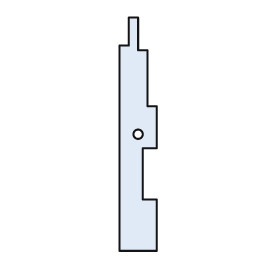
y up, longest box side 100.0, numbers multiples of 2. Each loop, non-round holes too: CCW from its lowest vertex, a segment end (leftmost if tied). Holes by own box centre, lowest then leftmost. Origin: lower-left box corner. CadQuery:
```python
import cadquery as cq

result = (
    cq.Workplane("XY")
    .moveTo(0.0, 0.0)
    .lineTo(16.0, 0.0)
    .lineTo(16.0, 22.0)
    .lineTo(10.0, 22.0)
    .lineTo(10.0, 44.0)
    .lineTo(16.0, 44.0)
    .lineTo(16.0, 62.0)
    .lineTo(12.0, 62.0)
    .lineTo(12.0, 86.0)
    .lineTo(8.0, 86.0)
    .lineTo(8.0, 100.0)
    .lineTo(4.0, 100.0)
    .lineTo(4.0, 88.0)
    .lineTo(0.0, 88.0)
    .close()
    .moveTo(8.0, 50.0)
    .circle(2.0)
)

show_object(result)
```